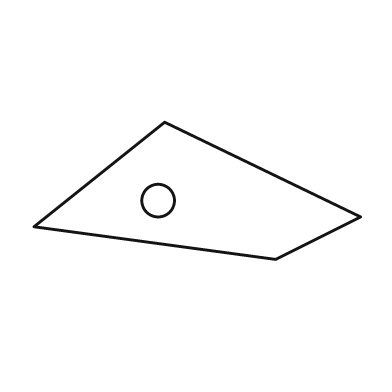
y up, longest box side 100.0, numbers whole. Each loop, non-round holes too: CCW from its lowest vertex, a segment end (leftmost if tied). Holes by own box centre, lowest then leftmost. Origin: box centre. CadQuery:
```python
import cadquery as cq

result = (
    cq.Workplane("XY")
    .moveTo(24.0, -21.0)
    .lineTo(50.0, -8.0)
    .lineTo(-10.0, 21.0)
    .lineTo(-50.0, -11.0)
    .close()
    .moveTo(-12.0, -3.0)
    .circle(5.0)
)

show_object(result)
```